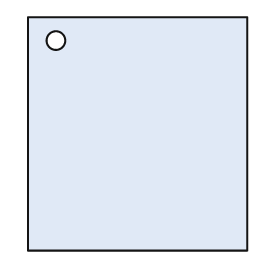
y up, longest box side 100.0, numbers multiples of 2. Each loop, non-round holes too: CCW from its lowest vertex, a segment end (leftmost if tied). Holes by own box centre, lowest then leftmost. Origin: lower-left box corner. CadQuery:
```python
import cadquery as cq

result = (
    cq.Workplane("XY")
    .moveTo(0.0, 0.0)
    .lineTo(94.0, 0.0)
    .lineTo(94.0, 100.0)
    .lineTo(0.0, 100.0)
    .close()
    .moveTo(12.0, 90.0)
    .circle(4.0)
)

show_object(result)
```